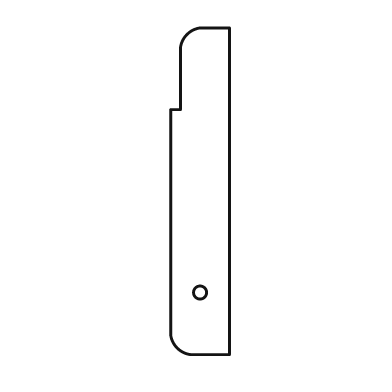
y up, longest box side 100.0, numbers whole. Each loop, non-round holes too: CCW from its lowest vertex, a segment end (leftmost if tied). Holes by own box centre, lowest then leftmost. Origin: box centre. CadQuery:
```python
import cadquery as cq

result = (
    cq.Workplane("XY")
    .moveTo(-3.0, -50.0)
    .lineTo(9.0, -50.0)
    .lineTo(9.0, 50.0)
    .lineTo(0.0, 50.0)
    .threePointArc((-4.0, 48.0), (-6.0, 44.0))
    .lineTo(-6.0, 25.0)
    .lineTo(-9.0, 25.0)
    .lineTo(-9.0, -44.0)
    .threePointArc((-7.0, -48.0), (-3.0, -50.0))
    .close()
    .moveTo(0.0, -31.0)
    .circle(2.0)
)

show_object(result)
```